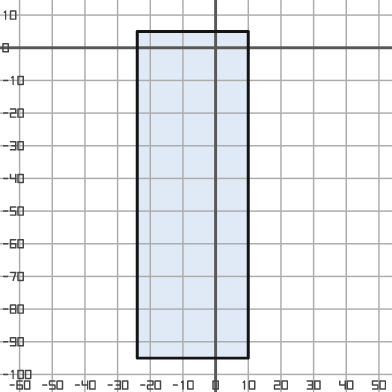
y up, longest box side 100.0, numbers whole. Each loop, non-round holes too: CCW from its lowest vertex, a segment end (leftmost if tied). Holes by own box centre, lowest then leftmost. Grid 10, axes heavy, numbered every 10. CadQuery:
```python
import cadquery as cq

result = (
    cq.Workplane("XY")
    .moveTo(-24.0, -95.0)
    .lineTo(10.0, -95.0)
    .lineTo(10.0, 5.0)
    .lineTo(-24.0, 5.0)
    .close()
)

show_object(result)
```